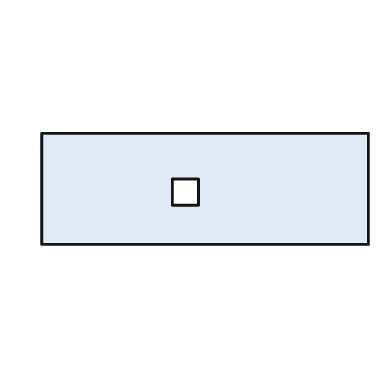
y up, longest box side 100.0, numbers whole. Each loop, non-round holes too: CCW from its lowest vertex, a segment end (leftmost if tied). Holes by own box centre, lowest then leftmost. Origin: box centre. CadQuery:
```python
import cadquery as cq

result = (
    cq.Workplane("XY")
    .moveTo(-50.0, -17.0)
    .lineTo(50.0, -17.0)
    .lineTo(50.0, 17.0)
    .lineTo(-50.0, 17.0)
    .close()
    .moveTo(-10.0, -5.0)
    .lineTo(-2.0, -5.0)
    .lineTo(-2.0, 3.0)
    .lineTo(-10.0, 3.0)
    .close()
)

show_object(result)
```